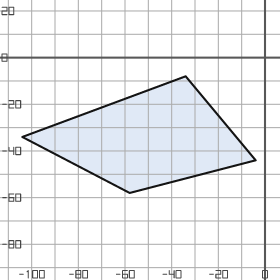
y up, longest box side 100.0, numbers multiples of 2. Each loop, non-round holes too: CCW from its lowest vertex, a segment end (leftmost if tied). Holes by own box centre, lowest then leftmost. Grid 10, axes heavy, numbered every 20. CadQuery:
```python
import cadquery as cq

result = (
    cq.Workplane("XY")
    .moveTo(-58.0, -58.0)
    .lineTo(-4.0, -44.0)
    .lineTo(-34.0, -8.0)
    .lineTo(-104.0, -34.0)
    .close()
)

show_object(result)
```